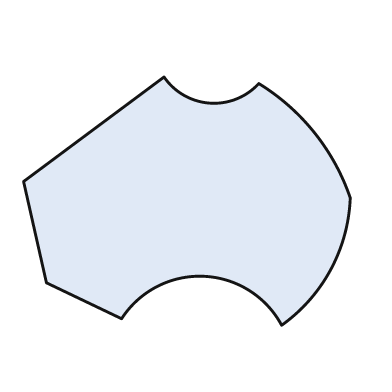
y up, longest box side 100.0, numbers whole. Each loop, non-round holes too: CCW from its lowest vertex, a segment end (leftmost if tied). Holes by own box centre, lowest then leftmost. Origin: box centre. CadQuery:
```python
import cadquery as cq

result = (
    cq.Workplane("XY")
    .moveTo(29.0, -38.0)
    .threePointArc((44.0, -21.0), (50.0, 1.0))
    .threePointArc((39.0, 21.0), (22.0, 36.0))
    .threePointArc((7.0, 30.0), (-7.0, 38.0))
    .lineTo(-50.0, 6.0)
    .lineTo(-43.0, -25.0)
    .lineTo(-20.0, -36.0)
    .threePointArc((5.0, -23.0), (29.0, -38.0))
    .close()
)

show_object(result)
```